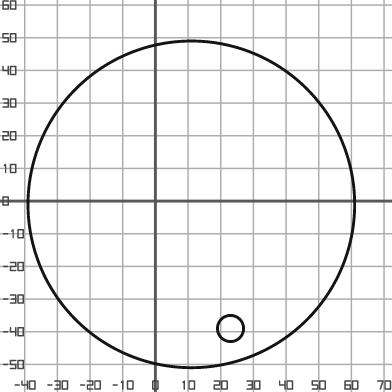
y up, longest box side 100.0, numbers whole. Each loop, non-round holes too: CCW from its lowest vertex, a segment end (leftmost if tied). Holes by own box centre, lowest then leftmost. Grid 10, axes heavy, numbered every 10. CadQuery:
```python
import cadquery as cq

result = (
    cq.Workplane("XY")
    .moveTo(11.0, -1.0)
    .circle(50.0)
    .moveTo(23.0, -39.0)
    .circle(4.0)
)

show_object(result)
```